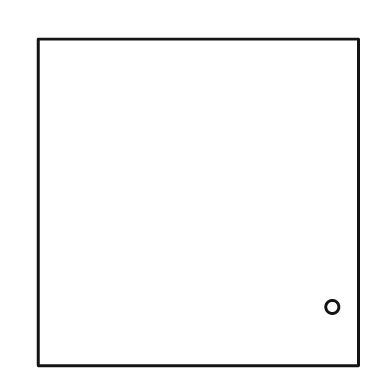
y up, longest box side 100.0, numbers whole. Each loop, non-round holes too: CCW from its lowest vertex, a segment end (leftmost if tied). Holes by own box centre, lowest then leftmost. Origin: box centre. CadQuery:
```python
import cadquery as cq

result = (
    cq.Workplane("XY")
    .moveTo(-49.0, -50.0)
    .lineTo(49.0, -50.0)
    .lineTo(49.0, 50.0)
    .lineTo(-49.0, 50.0)
    .close()
    .moveTo(41.0, -32.0)
    .circle(2.0)
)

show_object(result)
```